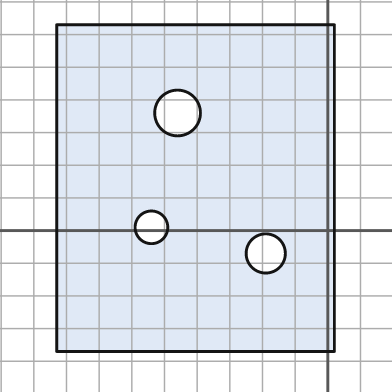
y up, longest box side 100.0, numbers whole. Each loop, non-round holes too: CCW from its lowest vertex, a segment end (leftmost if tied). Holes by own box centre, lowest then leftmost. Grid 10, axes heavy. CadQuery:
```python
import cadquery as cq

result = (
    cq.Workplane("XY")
    .moveTo(-83.0, -37.0)
    .lineTo(2.0, -37.0)
    .lineTo(2.0, 63.0)
    .lineTo(-83.0, 63.0)
    .close()
    .moveTo(-19.0, -7.0)
    .circle(6.0)
    .moveTo(-54.0, 1.0)
    .circle(5.0)
    .moveTo(-46.0, 36.0)
    .circle(7.0)
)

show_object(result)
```